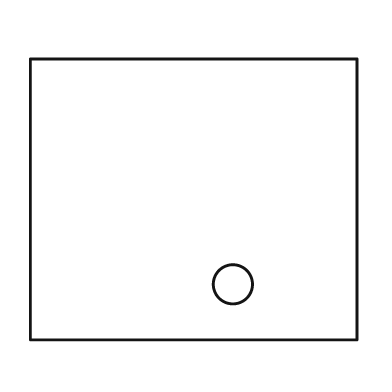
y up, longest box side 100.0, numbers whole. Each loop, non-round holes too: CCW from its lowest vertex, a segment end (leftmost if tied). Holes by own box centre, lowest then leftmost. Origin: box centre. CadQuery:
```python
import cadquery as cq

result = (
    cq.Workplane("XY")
    .moveTo(-50.0, -43.0)
    .lineTo(50.0, -43.0)
    .lineTo(50.0, 43.0)
    .lineTo(-50.0, 43.0)
    .close()
    .moveTo(12.0, -26.0)
    .circle(6.0)
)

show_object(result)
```